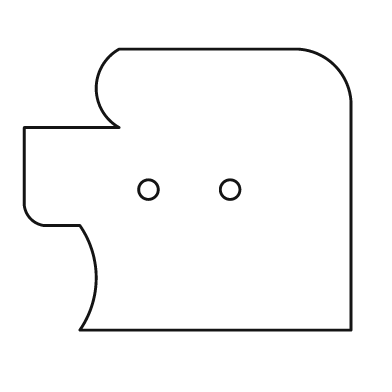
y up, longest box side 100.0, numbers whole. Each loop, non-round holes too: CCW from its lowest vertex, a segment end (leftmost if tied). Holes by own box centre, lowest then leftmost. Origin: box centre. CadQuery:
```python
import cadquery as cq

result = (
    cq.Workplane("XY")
    .moveTo(-33.0, -43.0)
    .lineTo(50.0, -43.0)
    .lineTo(50.0, 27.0)
    .threePointArc((45.0, 38.0), (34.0, 43.0))
    .lineTo(-21.0, 43.0)
    .threePointArc((-28.0, 31.0), (-21.0, 19.0))
    .lineTo(-50.0, 19.0)
    .lineTo(-50.0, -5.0)
    .threePointArc((-48.0, -9.0), (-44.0, -11.0))
    .lineTo(-33.0, -11.0)
    .threePointArc((-28.0, -27.0), (-33.0, -43.0))
    .close()
    .moveTo(-12.0, 0.0)
    .circle(3.0)
    .moveTo(13.0, 0.0)
    .circle(3.0)
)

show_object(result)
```